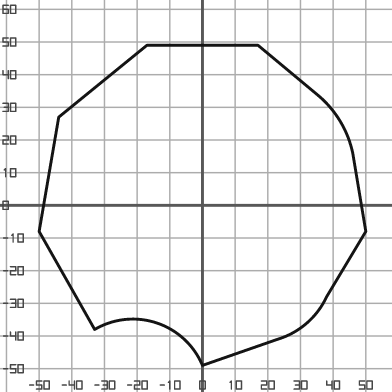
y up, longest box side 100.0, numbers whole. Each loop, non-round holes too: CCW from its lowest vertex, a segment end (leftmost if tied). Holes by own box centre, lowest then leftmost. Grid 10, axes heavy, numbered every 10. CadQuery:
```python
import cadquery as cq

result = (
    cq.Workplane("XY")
    .moveTo(0.0, -49.0)
    .lineTo(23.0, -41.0)
    .threePointArc((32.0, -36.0), (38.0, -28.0))
    .lineTo(50.0, -8.0)
    .lineTo(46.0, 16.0)
    .threePointArc((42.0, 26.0), (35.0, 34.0))
    .lineTo(17.0, 49.0)
    .lineTo(-17.0, 49.0)
    .lineTo(-44.0, 27.0)
    .lineTo(-50.0, -8.0)
    .lineTo(-33.0, -38.0)
    .threePointArc((-14.0, -36.0), (0.0, -49.0))
    .close()
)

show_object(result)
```